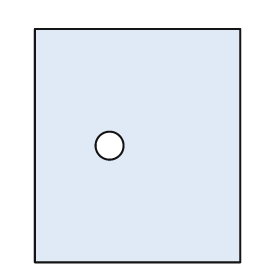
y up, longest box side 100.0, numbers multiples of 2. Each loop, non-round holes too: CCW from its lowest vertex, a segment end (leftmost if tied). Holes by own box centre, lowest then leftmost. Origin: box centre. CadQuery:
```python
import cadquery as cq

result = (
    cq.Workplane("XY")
    .moveTo(-44.0, -50.0)
    .lineTo(44.0, -50.0)
    .lineTo(44.0, 50.0)
    .lineTo(-44.0, 50.0)
    .close()
    .moveTo(-12.0, 0.0)
    .circle(6.0)
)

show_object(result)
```